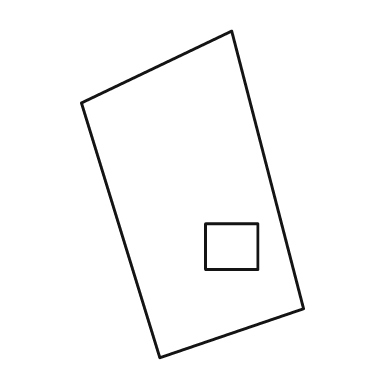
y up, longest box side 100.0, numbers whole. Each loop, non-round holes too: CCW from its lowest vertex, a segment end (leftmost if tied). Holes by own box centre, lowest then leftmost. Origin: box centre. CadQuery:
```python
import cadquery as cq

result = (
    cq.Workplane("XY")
    .moveTo(-10.0, -50.0)
    .lineTo(34.0, -35.0)
    .lineTo(12.0, 50.0)
    .lineTo(-34.0, 28.0)
    .close()
    .moveTo(4.0, -23.0)
    .lineTo(20.0, -23.0)
    .lineTo(20.0, -9.0)
    .lineTo(4.0, -9.0)
    .close()
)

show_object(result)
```